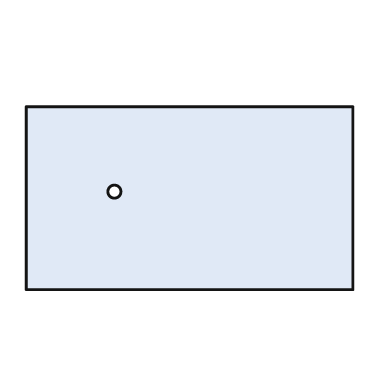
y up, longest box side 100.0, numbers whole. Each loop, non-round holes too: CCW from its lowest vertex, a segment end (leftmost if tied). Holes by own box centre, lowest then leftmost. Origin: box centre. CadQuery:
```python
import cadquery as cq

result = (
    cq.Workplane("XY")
    .moveTo(-50.0, -28.0)
    .lineTo(50.0, -28.0)
    .lineTo(50.0, 28.0)
    .lineTo(-50.0, 28.0)
    .close()
    .moveTo(-23.0, 2.0)
    .circle(2.0)
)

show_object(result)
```